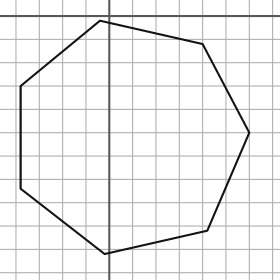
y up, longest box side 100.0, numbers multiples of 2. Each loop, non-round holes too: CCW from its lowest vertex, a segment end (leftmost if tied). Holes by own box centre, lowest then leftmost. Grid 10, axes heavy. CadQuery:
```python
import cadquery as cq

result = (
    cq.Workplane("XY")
    .moveTo(-2.0, -102.0)
    .lineTo(42.0, -92.0)
    .lineTo(60.0, -50.0)
    .lineTo(40.0, -12.0)
    .lineTo(-4.0, -2.0)
    .lineTo(-38.0, -30.0)
    .lineTo(-38.0, -74.0)
    .close()
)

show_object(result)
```